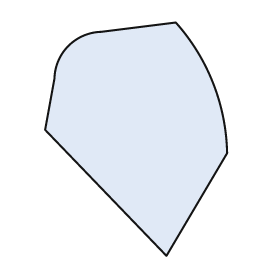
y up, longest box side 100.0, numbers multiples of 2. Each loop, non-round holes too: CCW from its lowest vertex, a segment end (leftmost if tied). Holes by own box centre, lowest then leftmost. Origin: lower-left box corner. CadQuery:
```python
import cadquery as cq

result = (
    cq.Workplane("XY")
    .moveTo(52.0, 0.0)
    .lineTo(78.0, 44.0)
    .threePointArc((72.0, 74.0), (56.0, 100.0))
    .lineTo(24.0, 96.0)
    .threePointArc((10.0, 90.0), (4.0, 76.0))
    .lineTo(0.0, 54.0)
    .close()
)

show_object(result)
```